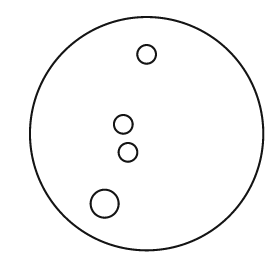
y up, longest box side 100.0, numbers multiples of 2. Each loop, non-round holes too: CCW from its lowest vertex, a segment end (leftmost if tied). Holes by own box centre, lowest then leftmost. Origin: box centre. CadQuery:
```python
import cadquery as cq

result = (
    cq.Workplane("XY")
    .moveTo(0.0, 0.0)
    .circle(50.0)
    .moveTo(-18.0, -30.0)
    .circle(6.0)
    .moveTo(-8.0, -8.0)
    .circle(4.0)
    .moveTo(-10.0, 4.0)
    .circle(4.0)
    .moveTo(0.0, 34.0)
    .circle(4.0)
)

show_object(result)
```